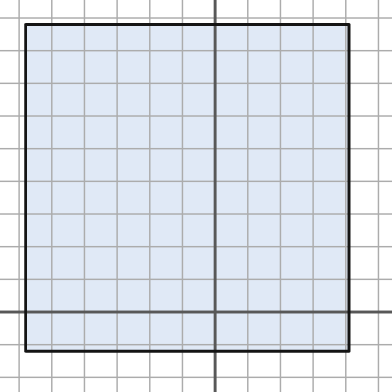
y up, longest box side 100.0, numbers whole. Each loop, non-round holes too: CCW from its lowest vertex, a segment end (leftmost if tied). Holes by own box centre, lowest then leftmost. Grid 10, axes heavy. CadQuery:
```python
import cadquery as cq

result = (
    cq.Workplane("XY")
    .moveTo(-58.0, -12.0)
    .lineTo(41.0, -12.0)
    .lineTo(41.0, 88.0)
    .lineTo(-58.0, 88.0)
    .close()
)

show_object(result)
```